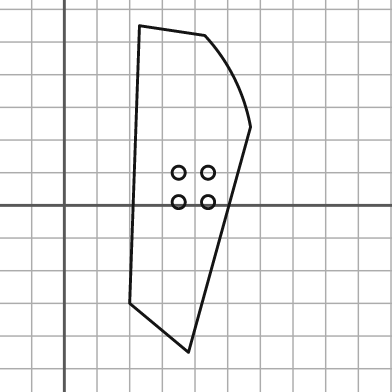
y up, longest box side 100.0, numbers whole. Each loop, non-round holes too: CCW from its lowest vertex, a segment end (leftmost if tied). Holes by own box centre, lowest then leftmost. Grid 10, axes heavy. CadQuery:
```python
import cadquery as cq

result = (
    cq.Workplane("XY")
    .moveTo(38.0, -45.0)
    .lineTo(57.0, 24.0)
    .threePointArc((52.0, 39.0), (43.0, 52.0))
    .lineTo(23.0, 55.0)
    .lineTo(20.0, -30.0)
    .close()
    .moveTo(35.0, 1.0)
    .circle(2.0)
    .moveTo(44.0, 1.0)
    .circle(2.0)
    .moveTo(35.0, 10.0)
    .circle(2.0)
    .moveTo(44.0, 10.0)
    .circle(2.0)
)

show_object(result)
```